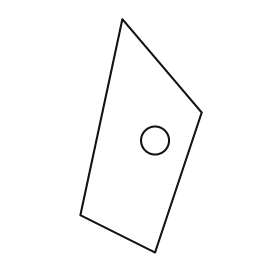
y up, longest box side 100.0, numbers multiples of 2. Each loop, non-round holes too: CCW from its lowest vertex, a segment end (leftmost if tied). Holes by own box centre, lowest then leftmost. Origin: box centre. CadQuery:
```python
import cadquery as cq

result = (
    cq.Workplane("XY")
    .moveTo(6.0, -50.0)
    .lineTo(26.0, 10.0)
    .lineTo(-8.0, 50.0)
    .lineTo(-26.0, -34.0)
    .close()
    .moveTo(6.0, -2.0)
    .circle(6.0)
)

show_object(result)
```